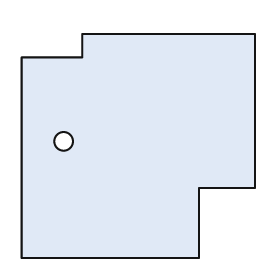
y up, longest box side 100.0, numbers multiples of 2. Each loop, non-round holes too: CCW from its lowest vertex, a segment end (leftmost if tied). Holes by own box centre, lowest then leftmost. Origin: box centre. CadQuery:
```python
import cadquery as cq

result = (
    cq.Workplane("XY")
    .moveTo(-50.0, -48.0)
    .lineTo(26.0, -48.0)
    .lineTo(26.0, -18.0)
    .lineTo(50.0, -18.0)
    .lineTo(50.0, 48.0)
    .lineTo(-24.0, 48.0)
    .lineTo(-24.0, 38.0)
    .lineTo(-50.0, 38.0)
    .close()
    .moveTo(-32.0, 2.0)
    .circle(4.0)
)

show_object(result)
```